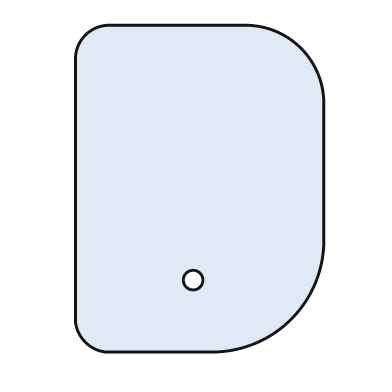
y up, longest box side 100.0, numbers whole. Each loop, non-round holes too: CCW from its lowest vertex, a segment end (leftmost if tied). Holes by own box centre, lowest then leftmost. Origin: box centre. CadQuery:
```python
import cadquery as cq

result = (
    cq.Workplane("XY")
    .moveTo(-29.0, -50.0)
    .lineTo(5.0, -50.0)
    .threePointArc((28.0, -40.0), (38.0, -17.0))
    .lineTo(38.0, 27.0)
    .threePointArc((31.0, 43.0), (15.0, 50.0))
    .lineTo(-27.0, 50.0)
    .threePointArc((-35.0, 47.0), (-38.0, 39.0))
    .lineTo(-38.0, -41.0)
    .threePointArc((-35.0, -47.0), (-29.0, -50.0))
    .close()
    .moveTo(-2.0, -28.0)
    .circle(3.0)
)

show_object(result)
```